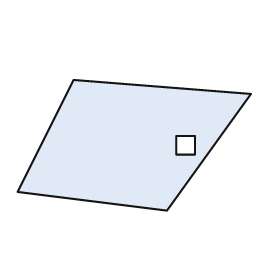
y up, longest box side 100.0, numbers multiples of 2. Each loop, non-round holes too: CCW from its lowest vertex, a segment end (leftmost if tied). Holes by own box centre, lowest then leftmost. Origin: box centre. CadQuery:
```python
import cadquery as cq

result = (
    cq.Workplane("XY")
    .moveTo(14.0, -28.0)
    .lineTo(50.0, 22.0)
    .lineTo(-26.0, 28.0)
    .lineTo(-50.0, -20.0)
    .close()
    .moveTo(18.0, -4.0)
    .lineTo(26.0, -4.0)
    .lineTo(26.0, 4.0)
    .lineTo(18.0, 4.0)
    .close()
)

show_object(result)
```